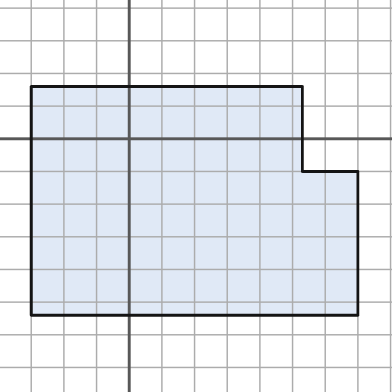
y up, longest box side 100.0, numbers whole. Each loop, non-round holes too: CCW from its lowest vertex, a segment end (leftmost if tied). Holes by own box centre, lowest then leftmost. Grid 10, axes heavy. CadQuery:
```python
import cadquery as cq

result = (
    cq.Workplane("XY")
    .moveTo(-30.0, -54.0)
    .lineTo(70.0, -54.0)
    .lineTo(70.0, -10.0)
    .lineTo(53.0, -10.0)
    .lineTo(53.0, 16.0)
    .lineTo(-30.0, 16.0)
    .close()
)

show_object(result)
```